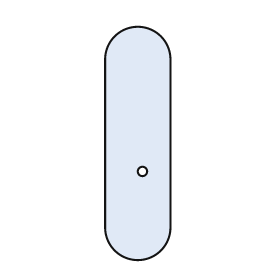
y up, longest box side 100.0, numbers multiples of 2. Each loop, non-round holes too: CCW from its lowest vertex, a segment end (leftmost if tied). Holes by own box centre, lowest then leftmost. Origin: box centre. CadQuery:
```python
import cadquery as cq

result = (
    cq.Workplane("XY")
    .moveTo(-14.0, -36.0)
    .threePointArc((0.0, -50.0), (14.0, -36.0))
    .lineTo(14.0, 36.0)
    .threePointArc((0.0, 50.0), (-14.0, 36.0))
    .close()
    .moveTo(2.0, -12.0)
    .circle(2.0)
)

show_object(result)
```